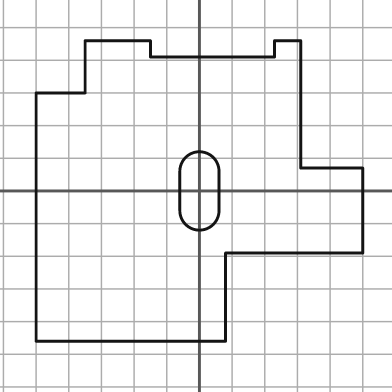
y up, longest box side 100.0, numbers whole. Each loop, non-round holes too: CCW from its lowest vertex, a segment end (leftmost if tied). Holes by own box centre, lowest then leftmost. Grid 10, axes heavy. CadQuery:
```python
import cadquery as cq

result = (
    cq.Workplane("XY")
    .moveTo(-50.0, -46.0)
    .lineTo(8.0, -46.0)
    .lineTo(8.0, -19.0)
    .lineTo(50.0, -19.0)
    .lineTo(50.0, 7.0)
    .lineTo(31.0, 7.0)
    .lineTo(31.0, 46.0)
    .lineTo(23.0, 46.0)
    .lineTo(23.0, 41.0)
    .lineTo(-15.0, 41.0)
    .lineTo(-15.0, 46.0)
    .lineTo(-35.0, 46.0)
    .lineTo(-35.0, 30.0)
    .lineTo(-50.0, 30.0)
    .close()
    .moveTo(-6.0, -6.0)
    .threePointArc((0.0, -12.0), (6.0, -6.0))
    .lineTo(6.0, 6.0)
    .threePointArc((0.0, 12.0), (-6.0, 6.0))
    .close()
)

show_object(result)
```